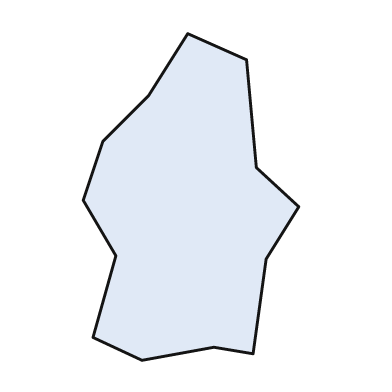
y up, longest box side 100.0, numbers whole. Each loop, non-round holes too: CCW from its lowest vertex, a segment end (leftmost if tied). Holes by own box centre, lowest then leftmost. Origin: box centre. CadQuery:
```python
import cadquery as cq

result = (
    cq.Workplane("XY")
    .moveTo(-15.0, -50.0)
    .lineTo(7.0, -46.0)
    .lineTo(19.0, -48.0)
    .lineTo(23.0, -19.0)
    .lineTo(33.0, -3.0)
    .lineTo(20.0, 9.0)
    .lineTo(17.0, 42.0)
    .lineTo(-1.0, 50.0)
    .lineTo(-13.0, 31.0)
    .lineTo(-27.0, 17.0)
    .lineTo(-33.0, -1.0)
    .lineTo(-23.0, -18.0)
    .lineTo(-30.0, -43.0)
    .close()
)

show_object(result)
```